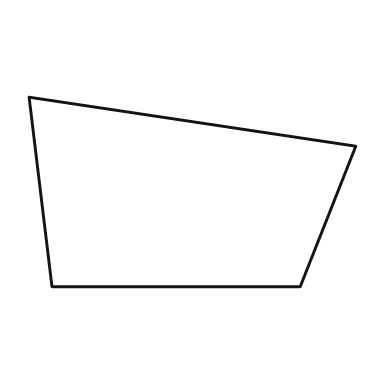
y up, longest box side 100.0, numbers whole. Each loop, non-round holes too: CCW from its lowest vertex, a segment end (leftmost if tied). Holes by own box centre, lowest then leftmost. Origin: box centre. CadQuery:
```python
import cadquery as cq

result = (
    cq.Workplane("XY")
    .moveTo(-43.0, -29.0)
    .lineTo(33.0, -29.0)
    .lineTo(50.0, 14.0)
    .lineTo(-50.0, 29.0)
    .close()
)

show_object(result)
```